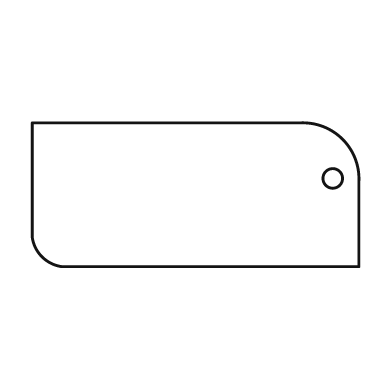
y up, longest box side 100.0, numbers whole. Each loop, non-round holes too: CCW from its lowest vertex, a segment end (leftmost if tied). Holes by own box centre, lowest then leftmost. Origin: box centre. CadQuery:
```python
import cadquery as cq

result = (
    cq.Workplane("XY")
    .moveTo(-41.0, -22.0)
    .lineTo(50.0, -22.0)
    .lineTo(50.0, 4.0)
    .threePointArc((45.0, 17.0), (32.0, 22.0))
    .lineTo(-50.0, 22.0)
    .lineTo(-50.0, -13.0)
    .threePointArc((-47.0, -19.0), (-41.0, -22.0))
    .close()
    .moveTo(42.0, 5.0)
    .circle(3.0)
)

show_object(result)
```